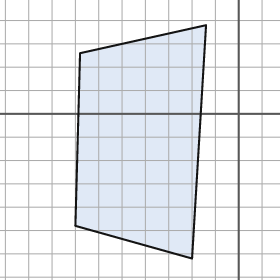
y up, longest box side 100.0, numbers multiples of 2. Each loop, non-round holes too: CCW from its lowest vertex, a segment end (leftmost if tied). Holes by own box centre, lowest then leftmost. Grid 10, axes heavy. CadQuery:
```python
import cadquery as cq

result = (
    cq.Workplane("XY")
    .moveTo(-20.0, -62.0)
    .lineTo(-14.0, 38.0)
    .lineTo(-68.0, 26.0)
    .lineTo(-70.0, -48.0)
    .close()
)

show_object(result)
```